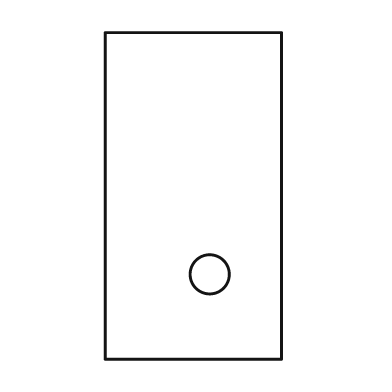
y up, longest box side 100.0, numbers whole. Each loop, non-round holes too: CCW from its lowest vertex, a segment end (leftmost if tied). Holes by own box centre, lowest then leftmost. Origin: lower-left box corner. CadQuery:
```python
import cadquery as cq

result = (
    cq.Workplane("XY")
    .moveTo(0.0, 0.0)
    .lineTo(54.0, 0.0)
    .lineTo(54.0, 100.0)
    .lineTo(0.0, 100.0)
    .close()
    .moveTo(32.0, 26.0)
    .circle(6.0)
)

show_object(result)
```